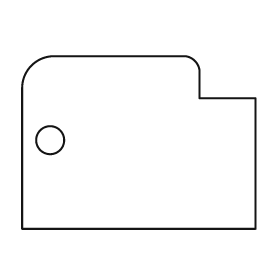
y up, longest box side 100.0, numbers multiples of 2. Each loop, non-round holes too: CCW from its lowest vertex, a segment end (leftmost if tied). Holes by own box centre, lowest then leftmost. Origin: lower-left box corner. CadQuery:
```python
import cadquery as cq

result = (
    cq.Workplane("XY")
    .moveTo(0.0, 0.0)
    .lineTo(100.0, 0.0)
    .lineTo(100.0, 56.0)
    .lineTo(76.0, 56.0)
    .lineTo(76.0, 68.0)
    .threePointArc((74.0, 72.0), (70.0, 74.0))
    .lineTo(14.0, 74.0)
    .threePointArc((4.0, 70.0), (0.0, 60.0))
    .close()
    .moveTo(12.0, 38.0)
    .circle(6.0)
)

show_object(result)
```